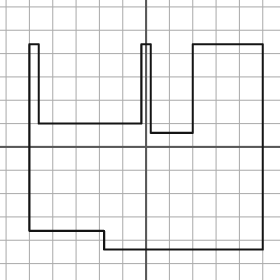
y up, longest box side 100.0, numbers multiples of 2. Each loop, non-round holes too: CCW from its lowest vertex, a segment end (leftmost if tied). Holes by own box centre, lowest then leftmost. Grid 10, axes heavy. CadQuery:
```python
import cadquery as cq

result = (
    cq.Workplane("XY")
    .moveTo(-18.0, -44.0)
    .lineTo(50.0, -44.0)
    .lineTo(50.0, 44.0)
    .lineTo(20.0, 44.0)
    .lineTo(20.0, 6.0)
    .lineTo(2.0, 6.0)
    .lineTo(2.0, 44.0)
    .lineTo(-2.0, 44.0)
    .lineTo(-2.0, 10.0)
    .lineTo(-46.0, 10.0)
    .lineTo(-46.0, 44.0)
    .lineTo(-50.0, 44.0)
    .lineTo(-50.0, -36.0)
    .lineTo(-18.0, -36.0)
    .close()
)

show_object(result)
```